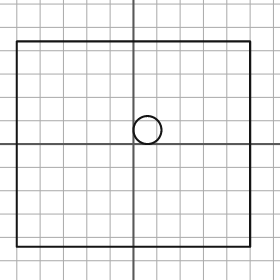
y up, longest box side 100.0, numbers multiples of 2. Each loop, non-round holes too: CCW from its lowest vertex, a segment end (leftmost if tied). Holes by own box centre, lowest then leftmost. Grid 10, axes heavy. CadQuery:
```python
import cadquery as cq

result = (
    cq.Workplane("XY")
    .moveTo(-50.0, -44.0)
    .lineTo(50.0, -44.0)
    .lineTo(50.0, 44.0)
    .lineTo(-50.0, 44.0)
    .close()
    .moveTo(6.0, 6.0)
    .circle(6.0)
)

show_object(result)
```